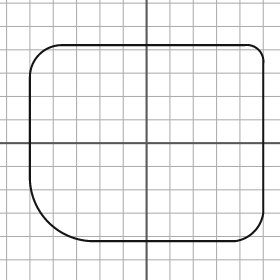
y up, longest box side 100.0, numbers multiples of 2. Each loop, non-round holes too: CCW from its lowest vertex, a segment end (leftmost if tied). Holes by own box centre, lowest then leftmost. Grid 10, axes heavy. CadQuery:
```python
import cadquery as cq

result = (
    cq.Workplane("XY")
    .moveTo(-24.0, -42.0)
    .lineTo(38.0, -42.0)
    .threePointArc((46.0, -38.0), (50.0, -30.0))
    .lineTo(50.0, 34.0)
    .threePointArc((48.0, 40.0), (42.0, 42.0))
    .lineTo(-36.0, 42.0)
    .threePointArc((-46.0, 38.0), (-50.0, 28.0))
    .lineTo(-50.0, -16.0)
    .threePointArc((-42.0, -34.0), (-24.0, -42.0))
    .close()
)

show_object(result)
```